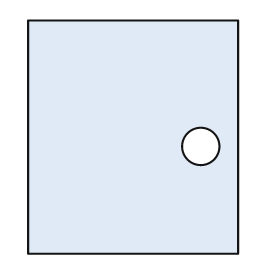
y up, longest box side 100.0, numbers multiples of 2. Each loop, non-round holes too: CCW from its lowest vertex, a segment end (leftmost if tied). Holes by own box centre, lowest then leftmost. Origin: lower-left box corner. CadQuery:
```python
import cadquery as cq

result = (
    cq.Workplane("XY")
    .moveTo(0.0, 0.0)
    .lineTo(90.0, 0.0)
    .lineTo(90.0, 100.0)
    .lineTo(0.0, 100.0)
    .close()
    .moveTo(74.0, 46.0)
    .circle(8.0)
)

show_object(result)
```